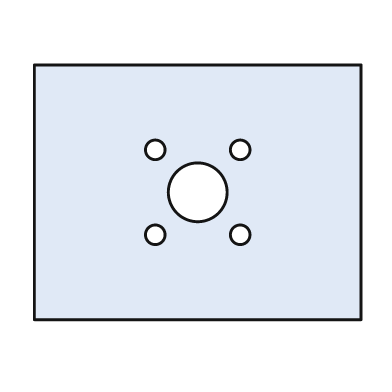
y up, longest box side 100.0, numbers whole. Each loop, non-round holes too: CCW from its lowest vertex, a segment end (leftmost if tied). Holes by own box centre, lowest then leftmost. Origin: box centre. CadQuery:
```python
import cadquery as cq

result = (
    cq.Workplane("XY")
    .moveTo(-50.0, -39.0)
    .lineTo(50.0, -39.0)
    .lineTo(50.0, 39.0)
    .lineTo(-50.0, 39.0)
    .close()
    .moveTo(-13.0, -13.0)
    .circle(3.0)
    .moveTo(13.0, -13.0)
    .circle(3.0)
    .moveTo(0.0, 0.0)
    .circle(9.0)
    .moveTo(-13.0, 13.0)
    .circle(3.0)
    .moveTo(13.0, 13.0)
    .circle(3.0)
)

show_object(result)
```